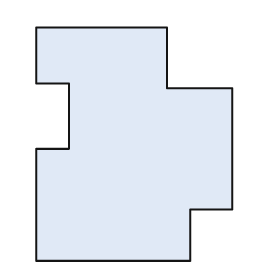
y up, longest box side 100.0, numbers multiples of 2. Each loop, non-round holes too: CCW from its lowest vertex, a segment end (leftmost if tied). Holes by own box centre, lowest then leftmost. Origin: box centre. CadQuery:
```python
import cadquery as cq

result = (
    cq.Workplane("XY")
    .moveTo(-42.0, -50.0)
    .lineTo(24.0, -50.0)
    .lineTo(24.0, -28.0)
    .lineTo(42.0, -28.0)
    .lineTo(42.0, 24.0)
    .lineTo(14.0, 24.0)
    .lineTo(14.0, 50.0)
    .lineTo(-42.0, 50.0)
    .lineTo(-42.0, 26.0)
    .lineTo(-28.0, 26.0)
    .lineTo(-28.0, -2.0)
    .lineTo(-42.0, -2.0)
    .close()
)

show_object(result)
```